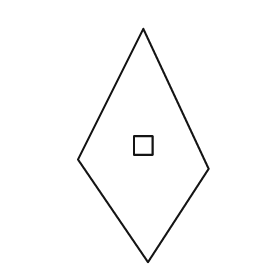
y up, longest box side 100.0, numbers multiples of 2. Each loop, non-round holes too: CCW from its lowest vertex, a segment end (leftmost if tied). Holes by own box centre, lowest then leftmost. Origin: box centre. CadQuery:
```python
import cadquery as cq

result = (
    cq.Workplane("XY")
    .moveTo(2.0, -50.0)
    .lineTo(28.0, -10.0)
    .lineTo(0.0, 50.0)
    .lineTo(-28.0, -6.0)
    .close()
    .moveTo(-4.0, -4.0)
    .lineTo(4.0, -4.0)
    .lineTo(4.0, 4.0)
    .lineTo(-4.0, 4.0)
    .close()
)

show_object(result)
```